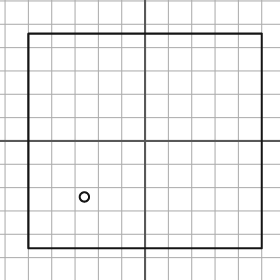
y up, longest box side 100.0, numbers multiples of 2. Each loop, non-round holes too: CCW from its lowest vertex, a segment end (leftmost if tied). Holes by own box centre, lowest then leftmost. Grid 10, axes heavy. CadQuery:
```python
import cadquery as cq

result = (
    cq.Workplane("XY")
    .moveTo(-50.0, -46.0)
    .lineTo(50.0, -46.0)
    .lineTo(50.0, 46.0)
    .lineTo(-50.0, 46.0)
    .close()
    .moveTo(-26.0, -24.0)
    .circle(2.0)
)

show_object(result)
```